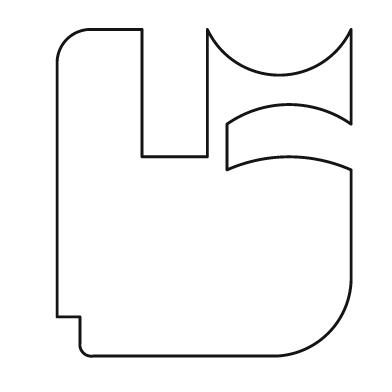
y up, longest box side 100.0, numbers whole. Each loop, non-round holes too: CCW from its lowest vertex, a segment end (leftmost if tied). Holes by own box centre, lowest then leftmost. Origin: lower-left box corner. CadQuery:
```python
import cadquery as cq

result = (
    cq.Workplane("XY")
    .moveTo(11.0, 0.0)
    .lineTo(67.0, 0.0)
    .threePointArc((83.0, 7.0), (90.0, 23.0))
    .lineTo(90.0, 57.0)
    .threePointArc((71.0, 61.0), (52.0, 57.0))
    .lineTo(52.0, 71.0)
    .threePointArc((71.0, 77.0), (90.0, 71.0))
    .lineTo(90.0, 100.0)
    .threePointArc((68.0, 86.0), (46.0, 100.0))
    .lineTo(46.0, 61.0)
    .lineTo(26.0, 61.0)
    .lineTo(26.0, 100.0)
    .lineTo(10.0, 100.0)
    .threePointArc((3.0, 97.0), (0.0, 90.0))
    .lineTo(0.0, 12.0)
    .lineTo(7.0, 12.0)
    .lineTo(7.0, 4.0)
    .threePointArc((8.0, 1.0), (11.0, 0.0))
    .close()
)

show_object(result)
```